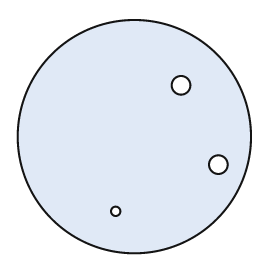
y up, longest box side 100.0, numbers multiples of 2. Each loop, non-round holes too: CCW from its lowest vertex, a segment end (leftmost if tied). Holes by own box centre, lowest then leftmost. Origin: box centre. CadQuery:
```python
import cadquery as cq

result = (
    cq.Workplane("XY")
    .moveTo(0.0, 0.0)
    .circle(50.0)
    .moveTo(-8.0, -32.0)
    .circle(2.0)
    .moveTo(36.0, -12.0)
    .circle(4.0)
    .moveTo(20.0, 22.0)
    .circle(4.0)
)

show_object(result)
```